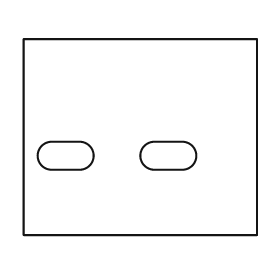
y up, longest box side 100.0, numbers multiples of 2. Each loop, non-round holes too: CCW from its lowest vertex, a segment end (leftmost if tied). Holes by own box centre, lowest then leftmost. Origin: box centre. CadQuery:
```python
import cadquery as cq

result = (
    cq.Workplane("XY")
    .moveTo(-50.0, -42.0)
    .lineTo(50.0, -42.0)
    .lineTo(50.0, 42.0)
    .lineTo(-50.0, 42.0)
    .close()
    .moveTo(-38.0, -14.0)
    .lineTo(-26.0, -14.0)
    .threePointArc((-20.0, -8.0), (-26.0, -2.0))
    .lineTo(-38.0, -2.0)
    .threePointArc((-44.0, -8.0), (-38.0, -14.0))
    .close()
    .moveTo(6.0, -14.0)
    .lineTo(18.0, -14.0)
    .threePointArc((24.0, -8.0), (18.0, -2.0))
    .lineTo(6.0, -2.0)
    .threePointArc((0.0, -8.0), (6.0, -14.0))
    .close()
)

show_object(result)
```